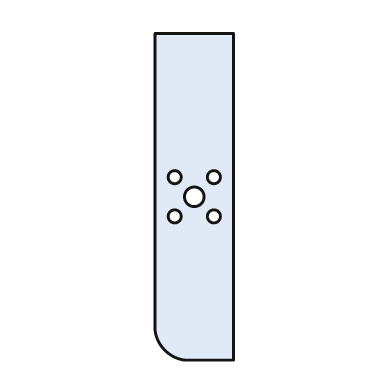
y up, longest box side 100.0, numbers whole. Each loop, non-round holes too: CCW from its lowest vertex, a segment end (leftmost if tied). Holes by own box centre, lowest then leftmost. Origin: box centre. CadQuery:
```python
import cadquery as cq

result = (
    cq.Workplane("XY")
    .moveTo(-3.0, -50.0)
    .lineTo(12.0, -50.0)
    .lineTo(12.0, 50.0)
    .lineTo(-12.0, 50.0)
    .lineTo(-12.0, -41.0)
    .threePointArc((-9.0, -47.0), (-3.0, -50.0))
    .close()
    .moveTo(-6.0, -6.0)
    .circle(2.0)
    .moveTo(6.0, -6.0)
    .circle(2.0)
    .moveTo(0.0, 0.0)
    .circle(3.0)
    .moveTo(-6.0, 6.0)
    .circle(2.0)
    .moveTo(6.0, 6.0)
    .circle(2.0)
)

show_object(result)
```